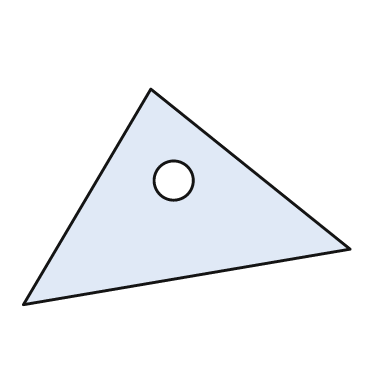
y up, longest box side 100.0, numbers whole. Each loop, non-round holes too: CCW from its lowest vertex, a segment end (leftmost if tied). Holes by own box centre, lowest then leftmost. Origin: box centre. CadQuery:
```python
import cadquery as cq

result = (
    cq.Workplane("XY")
    .moveTo(-50.0, -33.0)
    .lineTo(50.0, -16.0)
    .lineTo(-11.0, 33.0)
    .close()
    .moveTo(-4.0, 5.0)
    .circle(6.0)
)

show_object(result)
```